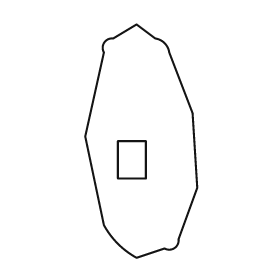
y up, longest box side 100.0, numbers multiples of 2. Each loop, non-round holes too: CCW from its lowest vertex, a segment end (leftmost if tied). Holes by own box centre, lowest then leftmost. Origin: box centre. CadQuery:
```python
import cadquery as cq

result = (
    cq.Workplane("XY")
    .moveTo(-2.0, -50.0)
    .lineTo(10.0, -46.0)
    .threePointArc((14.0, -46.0), (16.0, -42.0))
    .lineTo(24.0, -20.0)
    .lineTo(22.0, 12.0)
    .lineTo(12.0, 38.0)
    .threePointArc((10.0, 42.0), (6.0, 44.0))
    .lineTo(-2.0, 50.0)
    .lineTo(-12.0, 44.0)
    .threePointArc((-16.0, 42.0), (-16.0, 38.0))
    .lineTo(-24.0, 2.0)
    .lineTo(-16.0, -36.0)
    .threePointArc((-10.0, -44.0), (-2.0, -50.0))
    .close()
    .moveTo(-10.0, -16.0)
    .lineTo(2.0, -16.0)
    .lineTo(2.0, 0.0)
    .lineTo(-10.0, 0.0)
    .close()
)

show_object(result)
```